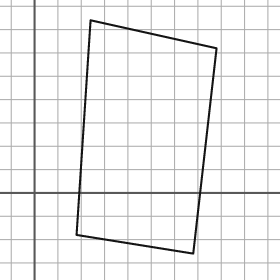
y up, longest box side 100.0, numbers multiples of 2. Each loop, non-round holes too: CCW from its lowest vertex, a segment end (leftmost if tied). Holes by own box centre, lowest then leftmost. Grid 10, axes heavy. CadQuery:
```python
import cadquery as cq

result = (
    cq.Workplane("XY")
    .moveTo(68.0, -26.0)
    .lineTo(78.0, 62.0)
    .lineTo(24.0, 74.0)
    .lineTo(18.0, -18.0)
    .close()
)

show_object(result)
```